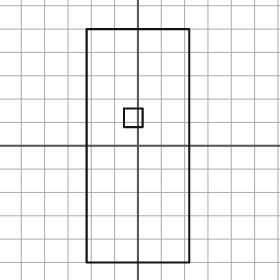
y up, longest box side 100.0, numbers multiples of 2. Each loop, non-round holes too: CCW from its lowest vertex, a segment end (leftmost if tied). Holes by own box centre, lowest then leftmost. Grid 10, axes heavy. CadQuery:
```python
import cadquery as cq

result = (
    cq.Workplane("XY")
    .moveTo(-22.0, -50.0)
    .lineTo(22.0, -50.0)
    .lineTo(22.0, 50.0)
    .lineTo(-22.0, 50.0)
    .close()
    .moveTo(-6.0, 8.0)
    .lineTo(2.0, 8.0)
    .lineTo(2.0, 16.0)
    .lineTo(-6.0, 16.0)
    .close()
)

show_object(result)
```